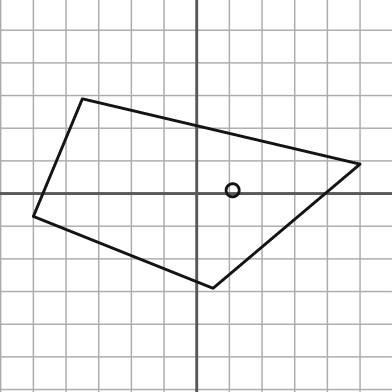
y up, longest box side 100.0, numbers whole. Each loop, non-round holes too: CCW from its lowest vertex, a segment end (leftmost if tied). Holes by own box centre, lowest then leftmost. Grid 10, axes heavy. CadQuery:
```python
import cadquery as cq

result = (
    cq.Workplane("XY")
    .moveTo(5.0, -29.0)
    .lineTo(50.0, 9.0)
    .lineTo(-35.0, 29.0)
    .lineTo(-50.0, -7.0)
    .close()
    .moveTo(11.0, 1.0)
    .circle(2.0)
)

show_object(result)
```